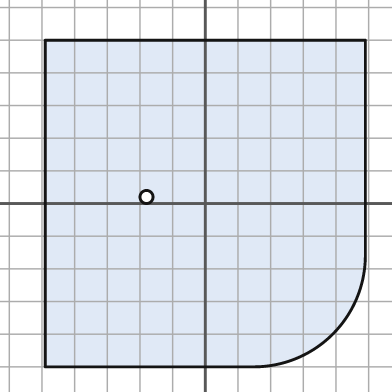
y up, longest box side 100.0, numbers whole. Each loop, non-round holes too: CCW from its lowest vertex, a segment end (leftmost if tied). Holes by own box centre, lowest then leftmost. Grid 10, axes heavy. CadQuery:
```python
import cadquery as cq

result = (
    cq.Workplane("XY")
    .moveTo(-49.0, -50.0)
    .lineTo(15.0, -50.0)
    .threePointArc((39.0, -40.0), (49.0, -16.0))
    .lineTo(49.0, 50.0)
    .lineTo(-49.0, 50.0)
    .close()
    .moveTo(-18.0, 2.0)
    .circle(2.0)
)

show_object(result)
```